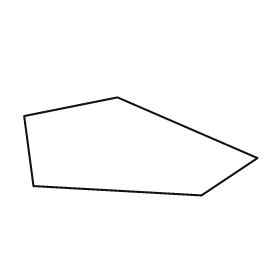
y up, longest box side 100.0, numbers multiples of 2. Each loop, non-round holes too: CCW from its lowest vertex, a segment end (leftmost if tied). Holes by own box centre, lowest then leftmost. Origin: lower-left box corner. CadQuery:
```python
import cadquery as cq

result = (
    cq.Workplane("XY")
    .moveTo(76.0, 0.0)
    .lineTo(100.0, 16.0)
    .lineTo(40.0, 42.0)
    .lineTo(0.0, 34.0)
    .lineTo(4.0, 4.0)
    .close()
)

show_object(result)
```